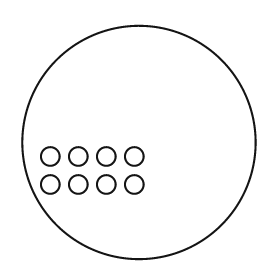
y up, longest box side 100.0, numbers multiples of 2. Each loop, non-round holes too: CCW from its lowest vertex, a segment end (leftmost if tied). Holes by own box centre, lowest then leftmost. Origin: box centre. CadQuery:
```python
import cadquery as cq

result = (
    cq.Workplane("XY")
    .moveTo(0.0, 0.0)
    .circle(50.0)
    .moveTo(-38.0, -18.0)
    .circle(4.0)
    .moveTo(-26.0, -18.0)
    .circle(4.0)
    .moveTo(-14.0, -18.0)
    .circle(4.0)
    .moveTo(-2.0, -18.0)
    .circle(4.0)
    .moveTo(-38.0, -6.0)
    .circle(4.0)
    .moveTo(-26.0, -6.0)
    .circle(4.0)
    .moveTo(-14.0, -6.0)
    .circle(4.0)
    .moveTo(-2.0, -6.0)
    .circle(4.0)
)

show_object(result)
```